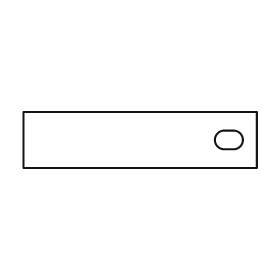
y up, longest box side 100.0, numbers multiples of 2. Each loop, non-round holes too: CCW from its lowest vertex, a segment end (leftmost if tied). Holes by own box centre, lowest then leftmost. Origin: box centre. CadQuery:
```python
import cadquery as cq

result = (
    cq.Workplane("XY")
    .moveTo(-50.0, -12.0)
    .lineTo(50.0, -12.0)
    .lineTo(50.0, 12.0)
    .lineTo(-50.0, 12.0)
    .close()
    .moveTo(36.0, -4.0)
    .lineTo(40.0, -4.0)
    .threePointArc((44.0, 0.0), (40.0, 4.0))
    .lineTo(36.0, 4.0)
    .threePointArc((32.0, 0.0), (36.0, -4.0))
    .close()
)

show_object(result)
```